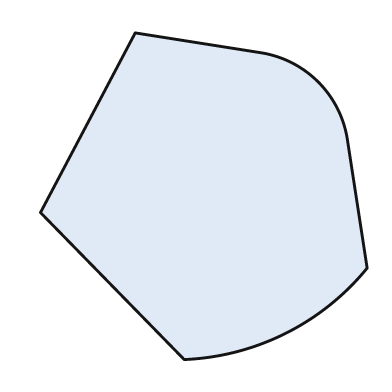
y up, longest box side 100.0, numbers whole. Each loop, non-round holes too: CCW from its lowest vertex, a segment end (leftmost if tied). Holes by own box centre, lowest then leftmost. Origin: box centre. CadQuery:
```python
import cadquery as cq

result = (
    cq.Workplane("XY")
    .moveTo(-6.0, -50.0)
    .threePointArc((25.0, -42.0), (50.0, -22.0))
    .lineTo(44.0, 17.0)
    .threePointArc((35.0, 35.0), (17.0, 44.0))
    .lineTo(-21.0, 50.0)
    .lineTo(-50.0, -5.0)
    .close()
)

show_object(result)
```